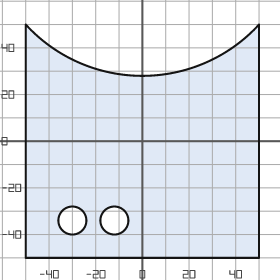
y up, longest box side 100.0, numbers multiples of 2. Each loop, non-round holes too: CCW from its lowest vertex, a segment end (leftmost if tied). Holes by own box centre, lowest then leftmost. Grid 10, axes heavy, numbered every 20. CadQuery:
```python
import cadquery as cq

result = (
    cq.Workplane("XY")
    .moveTo(-50.0, -50.0)
    .lineTo(50.0, -50.0)
    .lineTo(50.0, 50.0)
    .threePointArc((0.0, 28.0), (-50.0, 50.0))
    .close()
    .moveTo(-30.0, -34.0)
    .circle(6.0)
    .moveTo(-12.0, -34.0)
    .circle(6.0)
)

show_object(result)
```